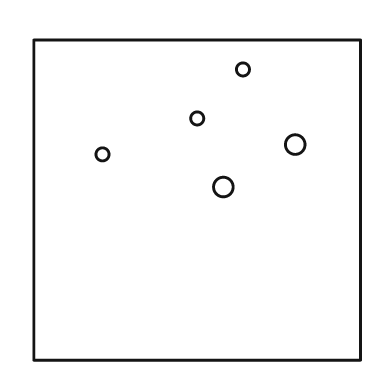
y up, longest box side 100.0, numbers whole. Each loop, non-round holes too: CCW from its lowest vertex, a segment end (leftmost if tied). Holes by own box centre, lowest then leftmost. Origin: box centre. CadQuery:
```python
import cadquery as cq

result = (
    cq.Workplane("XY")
    .moveTo(-50.0, -49.0)
    .lineTo(50.0, -49.0)
    .lineTo(50.0, 49.0)
    .lineTo(-50.0, 49.0)
    .close()
    .moveTo(8.0, 4.0)
    .circle(3.0)
    .moveTo(-29.0, 14.0)
    .circle(2.0)
    .moveTo(30.0, 17.0)
    .circle(3.0)
    .moveTo(0.0, 25.0)
    .circle(2.0)
    .moveTo(14.0, 40.0)
    .circle(2.0)
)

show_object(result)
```